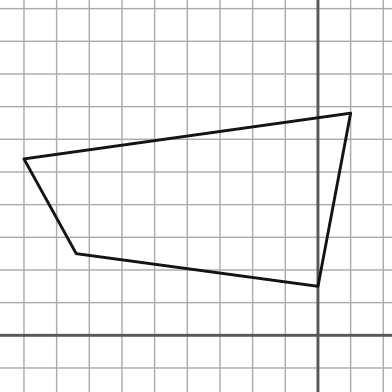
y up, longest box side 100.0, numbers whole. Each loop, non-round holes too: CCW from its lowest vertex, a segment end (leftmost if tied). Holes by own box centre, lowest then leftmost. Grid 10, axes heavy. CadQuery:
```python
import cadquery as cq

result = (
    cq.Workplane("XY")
    .moveTo(0.0, 15.0)
    .lineTo(10.0, 68.0)
    .lineTo(-90.0, 54.0)
    .lineTo(-74.0, 25.0)
    .close()
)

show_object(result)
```